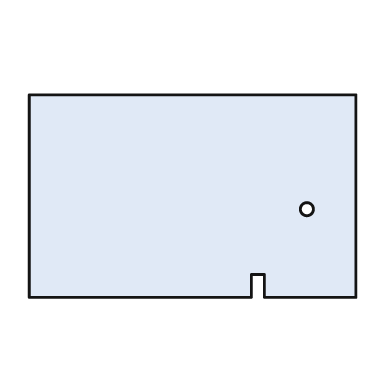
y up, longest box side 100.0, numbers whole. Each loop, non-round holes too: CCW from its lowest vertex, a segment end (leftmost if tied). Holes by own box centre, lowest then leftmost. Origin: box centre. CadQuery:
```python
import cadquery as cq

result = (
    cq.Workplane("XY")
    .moveTo(-50.0, -31.0)
    .lineTo(18.0, -31.0)
    .lineTo(18.0, -24.0)
    .lineTo(22.0, -24.0)
    .lineTo(22.0, -31.0)
    .lineTo(50.0, -31.0)
    .lineTo(50.0, 31.0)
    .lineTo(-50.0, 31.0)
    .close()
    .moveTo(35.0, -4.0)
    .circle(2.0)
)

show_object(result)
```